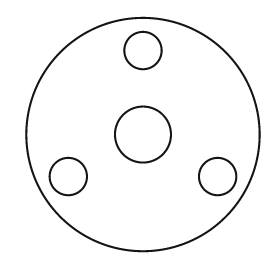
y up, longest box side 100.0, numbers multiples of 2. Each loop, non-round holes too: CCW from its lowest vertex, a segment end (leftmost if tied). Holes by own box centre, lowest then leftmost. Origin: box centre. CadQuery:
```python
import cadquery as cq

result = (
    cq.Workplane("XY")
    .moveTo(0.0, 0.0)
    .circle(50.0)
    .moveTo(-32.0, -18.0)
    .circle(8.0)
    .moveTo(32.0, -18.0)
    .circle(8.0)
    .moveTo(0.0, 0.0)
    .circle(12.0)
    .moveTo(0.0, 36.0)
    .circle(8.0)
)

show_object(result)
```